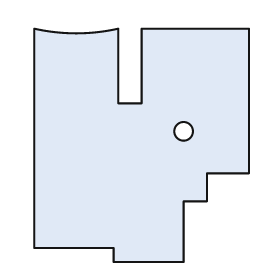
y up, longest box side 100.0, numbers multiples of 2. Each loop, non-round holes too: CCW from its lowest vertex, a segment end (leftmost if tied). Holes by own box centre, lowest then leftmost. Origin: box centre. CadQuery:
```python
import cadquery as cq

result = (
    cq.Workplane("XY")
    .moveTo(-12.0, -50.0)
    .lineTo(18.0, -50.0)
    .lineTo(18.0, -24.0)
    .lineTo(28.0, -24.0)
    .lineTo(28.0, -12.0)
    .lineTo(46.0, -12.0)
    .lineTo(46.0, 50.0)
    .lineTo(0.0, 50.0)
    .lineTo(0.0, 18.0)
    .lineTo(-10.0, 18.0)
    .lineTo(-10.0, 50.0)
    .threePointArc((-28.0, 48.0), (-46.0, 50.0))
    .lineTo(-46.0, -44.0)
    .lineTo(-12.0, -44.0)
    .close()
    .moveTo(18.0, 6.0)
    .circle(4.0)
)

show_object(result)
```